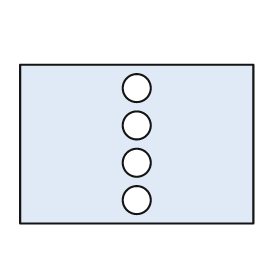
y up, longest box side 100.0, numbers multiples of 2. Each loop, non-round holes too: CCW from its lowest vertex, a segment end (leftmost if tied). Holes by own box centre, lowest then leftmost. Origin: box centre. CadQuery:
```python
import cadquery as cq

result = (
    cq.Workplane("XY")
    .moveTo(-50.0, -34.0)
    .lineTo(50.0, -34.0)
    .lineTo(50.0, 34.0)
    .lineTo(-50.0, 34.0)
    .close()
    .moveTo(0.0, -24.0)
    .circle(6.0)
    .moveTo(0.0, -8.0)
    .circle(6.0)
    .moveTo(0.0, 8.0)
    .circle(6.0)
    .moveTo(0.0, 24.0)
    .circle(6.0)
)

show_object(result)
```